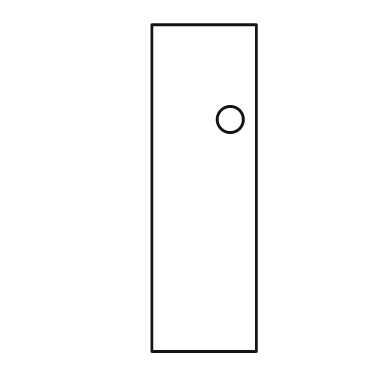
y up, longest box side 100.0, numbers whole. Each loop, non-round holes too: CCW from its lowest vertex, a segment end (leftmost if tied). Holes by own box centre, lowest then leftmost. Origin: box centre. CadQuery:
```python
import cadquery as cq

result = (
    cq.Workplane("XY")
    .moveTo(-16.0, -50.0)
    .lineTo(16.0, -50.0)
    .lineTo(16.0, 50.0)
    .lineTo(-16.0, 50.0)
    .close()
    .moveTo(8.0, 21.0)
    .circle(4.0)
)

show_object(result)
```